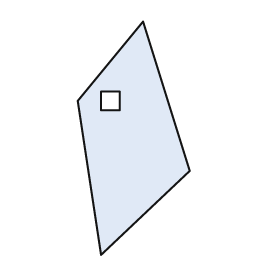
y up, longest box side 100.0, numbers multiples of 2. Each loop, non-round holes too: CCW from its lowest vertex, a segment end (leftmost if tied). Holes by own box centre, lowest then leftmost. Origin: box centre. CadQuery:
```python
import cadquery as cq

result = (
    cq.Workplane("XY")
    .moveTo(-14.0, -50.0)
    .lineTo(24.0, -14.0)
    .lineTo(4.0, 50.0)
    .lineTo(-24.0, 16.0)
    .close()
    .moveTo(-14.0, 12.0)
    .lineTo(-6.0, 12.0)
    .lineTo(-6.0, 20.0)
    .lineTo(-14.0, 20.0)
    .close()
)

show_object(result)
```